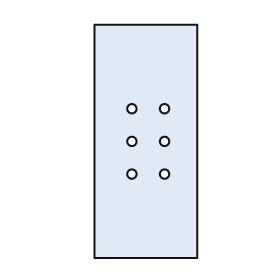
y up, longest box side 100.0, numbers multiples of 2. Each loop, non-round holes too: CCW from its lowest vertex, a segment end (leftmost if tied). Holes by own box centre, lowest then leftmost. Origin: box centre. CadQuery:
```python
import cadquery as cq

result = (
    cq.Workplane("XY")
    .moveTo(-22.0, -50.0)
    .lineTo(22.0, -50.0)
    .lineTo(22.0, 50.0)
    .lineTo(-22.0, 50.0)
    .close()
    .moveTo(-6.0, -14.0)
    .circle(2.0)
    .moveTo(8.0, -14.0)
    .circle(2.0)
    .moveTo(-6.0, 0.0)
    .circle(2.0)
    .moveTo(8.0, 0.0)
    .circle(2.0)
    .moveTo(-6.0, 14.0)
    .circle(2.0)
    .moveTo(8.0, 14.0)
    .circle(2.0)
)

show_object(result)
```